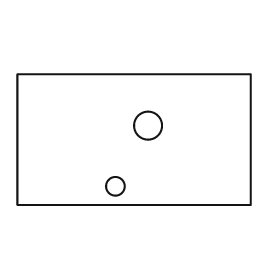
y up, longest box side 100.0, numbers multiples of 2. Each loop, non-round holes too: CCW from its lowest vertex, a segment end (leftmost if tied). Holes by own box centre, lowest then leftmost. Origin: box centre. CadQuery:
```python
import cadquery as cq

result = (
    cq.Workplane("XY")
    .moveTo(-50.0, -28.0)
    .lineTo(50.0, -28.0)
    .lineTo(50.0, 28.0)
    .lineTo(-50.0, 28.0)
    .close()
    .moveTo(-8.0, -20.0)
    .circle(4.0)
    .moveTo(6.0, 6.0)
    .circle(6.0)
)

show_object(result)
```